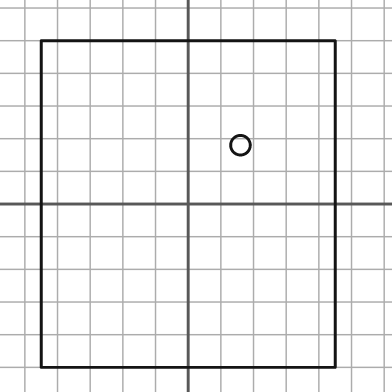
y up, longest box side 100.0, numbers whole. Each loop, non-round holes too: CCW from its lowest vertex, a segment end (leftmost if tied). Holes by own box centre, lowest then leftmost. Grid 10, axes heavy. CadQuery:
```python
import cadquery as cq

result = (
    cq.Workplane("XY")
    .moveTo(-45.0, -50.0)
    .lineTo(45.0, -50.0)
    .lineTo(45.0, 50.0)
    .lineTo(-45.0, 50.0)
    .close()
    .moveTo(16.0, 18.0)
    .circle(3.0)
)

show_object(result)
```